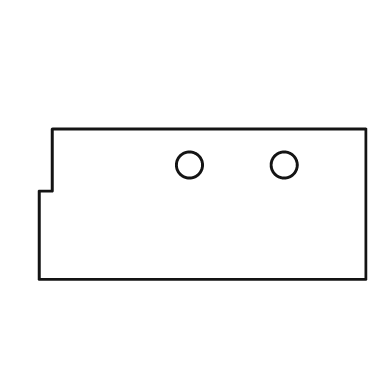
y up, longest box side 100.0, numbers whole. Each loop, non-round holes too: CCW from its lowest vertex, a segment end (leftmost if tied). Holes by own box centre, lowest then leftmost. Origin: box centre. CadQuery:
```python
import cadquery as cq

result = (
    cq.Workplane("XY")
    .moveTo(-50.0, -23.0)
    .lineTo(50.0, -23.0)
    .lineTo(50.0, 23.0)
    .lineTo(-46.0, 23.0)
    .lineTo(-46.0, 4.0)
    .lineTo(-50.0, 4.0)
    .close()
    .moveTo(-4.0, 12.0)
    .circle(4.0)
    .moveTo(25.0, 12.0)
    .circle(4.0)
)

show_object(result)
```